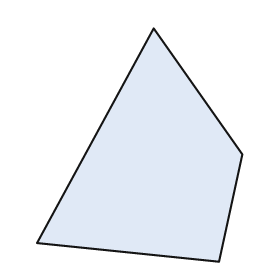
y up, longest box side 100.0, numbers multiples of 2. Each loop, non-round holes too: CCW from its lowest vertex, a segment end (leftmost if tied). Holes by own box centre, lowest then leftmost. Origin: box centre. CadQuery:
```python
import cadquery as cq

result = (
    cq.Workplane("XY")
    .moveTo(34.0, -50.0)
    .lineTo(44.0, -4.0)
    .lineTo(6.0, 50.0)
    .lineTo(-44.0, -42.0)
    .close()
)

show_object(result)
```